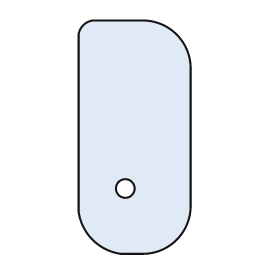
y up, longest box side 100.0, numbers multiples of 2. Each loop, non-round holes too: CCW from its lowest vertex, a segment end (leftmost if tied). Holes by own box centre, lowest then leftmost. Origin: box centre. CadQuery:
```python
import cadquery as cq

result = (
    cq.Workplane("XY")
    .moveTo(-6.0, -50.0)
    .lineTo(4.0, -50.0)
    .threePointArc((18.0, -44.0), (24.0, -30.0))
    .lineTo(24.0, 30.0)
    .threePointArc((18.0, 44.0), (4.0, 50.0))
    .lineTo(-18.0, 50.0)
    .threePointArc((-22.0, 48.0), (-24.0, 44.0))
    .lineTo(-24.0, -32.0)
    .threePointArc((-18.0, -44.0), (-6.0, -50.0))
    .close()
    .moveTo(-4.0, -22.0)
    .circle(4.0)
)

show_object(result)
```